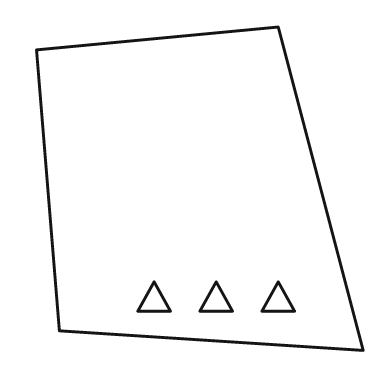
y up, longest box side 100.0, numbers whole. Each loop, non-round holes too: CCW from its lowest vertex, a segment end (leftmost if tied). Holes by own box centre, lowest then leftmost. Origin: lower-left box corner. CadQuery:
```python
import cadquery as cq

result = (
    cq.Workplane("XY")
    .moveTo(100.0, 0.0)
    .lineTo(74.0, 99.0)
    .lineTo(0.0, 92.0)
    .lineTo(7.0, 6.0)
    .close()
    .moveTo(31.0, 12.0)
    .lineTo(41.0, 12.0)
    .lineTo(36.0, 21.0)
    .close()
    .moveTo(50.0, 12.0)
    .lineTo(60.0, 12.0)
    .lineTo(55.0, 21.0)
    .close()
    .moveTo(69.0, 12.0)
    .lineTo(79.0, 12.0)
    .lineTo(74.0, 21.0)
    .close()
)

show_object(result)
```